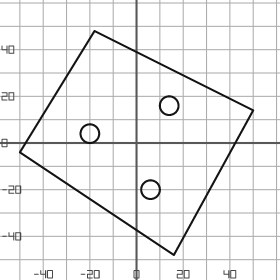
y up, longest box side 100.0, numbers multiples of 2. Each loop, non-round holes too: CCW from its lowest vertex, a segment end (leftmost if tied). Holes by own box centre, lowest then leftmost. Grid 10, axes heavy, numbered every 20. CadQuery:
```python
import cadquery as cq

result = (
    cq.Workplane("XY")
    .moveTo(16.0, -48.0)
    .lineTo(50.0, 14.0)
    .lineTo(-18.0, 48.0)
    .lineTo(-50.0, -4.0)
    .close()
    .moveTo(6.0, -20.0)
    .circle(4.0)
    .moveTo(-20.0, 4.0)
    .circle(4.0)
    .moveTo(14.0, 16.0)
    .circle(4.0)
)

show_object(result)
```